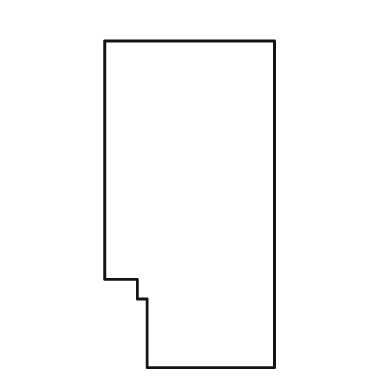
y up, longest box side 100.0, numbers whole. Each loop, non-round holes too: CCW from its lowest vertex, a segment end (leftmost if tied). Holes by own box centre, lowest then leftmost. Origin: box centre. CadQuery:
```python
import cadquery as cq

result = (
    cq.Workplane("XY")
    .moveTo(-13.0, -50.0)
    .lineTo(26.0, -50.0)
    .lineTo(26.0, 50.0)
    .lineTo(-26.0, 50.0)
    .lineTo(-26.0, -23.0)
    .lineTo(-16.0, -23.0)
    .lineTo(-16.0, -29.0)
    .lineTo(-13.0, -29.0)
    .close()
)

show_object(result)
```